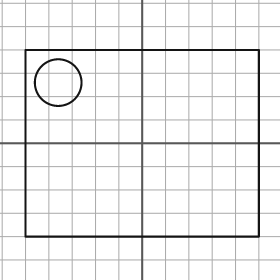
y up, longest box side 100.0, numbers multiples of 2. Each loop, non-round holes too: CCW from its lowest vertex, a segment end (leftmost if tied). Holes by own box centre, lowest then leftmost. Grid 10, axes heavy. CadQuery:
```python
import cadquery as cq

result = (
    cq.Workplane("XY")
    .moveTo(-50.0, -40.0)
    .lineTo(50.0, -40.0)
    .lineTo(50.0, 40.0)
    .lineTo(-50.0, 40.0)
    .close()
    .moveTo(-36.0, 26.0)
    .circle(10.0)
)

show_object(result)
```